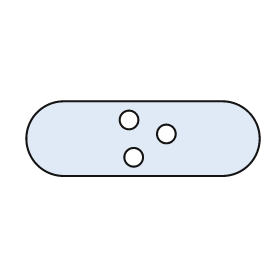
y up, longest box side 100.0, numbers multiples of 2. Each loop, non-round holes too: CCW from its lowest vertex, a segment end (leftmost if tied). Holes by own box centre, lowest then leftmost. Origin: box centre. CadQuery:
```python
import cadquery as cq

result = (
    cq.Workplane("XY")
    .moveTo(-34.0, -16.0)
    .lineTo(34.0, -16.0)
    .threePointArc((50.0, 0.0), (34.0, 16.0))
    .lineTo(-34.0, 16.0)
    .threePointArc((-50.0, 0.0), (-34.0, -16.0))
    .close()
    .moveTo(-4.0, -8.0)
    .circle(4.0)
    .moveTo(10.0, 2.0)
    .circle(4.0)
    .moveTo(-6.0, 8.0)
    .circle(4.0)
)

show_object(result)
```